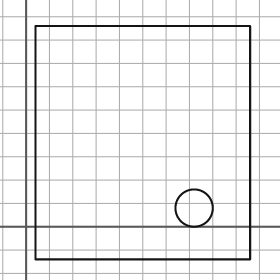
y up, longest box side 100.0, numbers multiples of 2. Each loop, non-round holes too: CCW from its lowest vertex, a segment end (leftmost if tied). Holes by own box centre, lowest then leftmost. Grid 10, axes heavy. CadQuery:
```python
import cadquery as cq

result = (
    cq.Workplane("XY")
    .moveTo(4.0, -14.0)
    .lineTo(96.0, -14.0)
    .lineTo(96.0, 86.0)
    .lineTo(4.0, 86.0)
    .close()
    .moveTo(72.0, 8.0)
    .circle(8.0)
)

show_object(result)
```